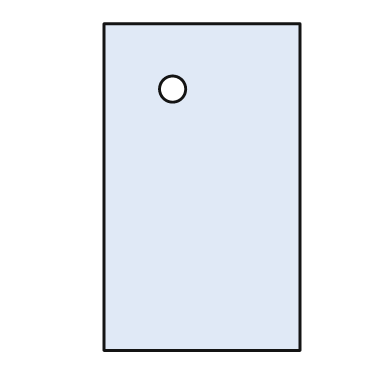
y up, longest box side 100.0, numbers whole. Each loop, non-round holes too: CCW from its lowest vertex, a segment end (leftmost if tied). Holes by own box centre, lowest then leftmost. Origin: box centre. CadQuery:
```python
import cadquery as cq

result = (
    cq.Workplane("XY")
    .moveTo(-30.0, -50.0)
    .lineTo(30.0, -50.0)
    .lineTo(30.0, 50.0)
    .lineTo(-30.0, 50.0)
    .close()
    .moveTo(-9.0, 30.0)
    .circle(4.0)
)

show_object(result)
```